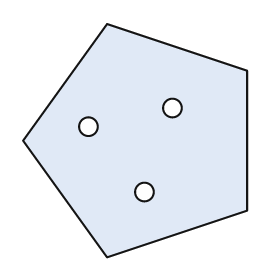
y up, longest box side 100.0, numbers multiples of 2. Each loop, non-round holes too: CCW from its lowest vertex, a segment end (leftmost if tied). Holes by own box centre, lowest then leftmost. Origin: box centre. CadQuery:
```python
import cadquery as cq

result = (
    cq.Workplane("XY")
    .moveTo(-12.0, -50.0)
    .lineTo(48.0, -30.0)
    .lineTo(48.0, 30.0)
    .lineTo(-12.0, 50.0)
    .lineTo(-48.0, 0.0)
    .close()
    .moveTo(4.0, -22.0)
    .circle(4.0)
    .moveTo(-20.0, 6.0)
    .circle(4.0)
    .moveTo(16.0, 14.0)
    .circle(4.0)
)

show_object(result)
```